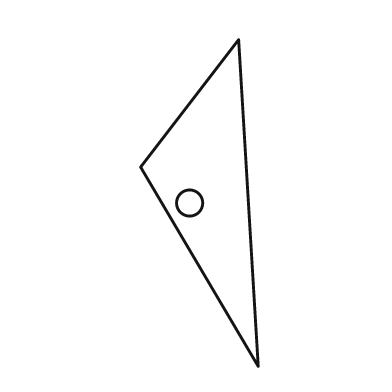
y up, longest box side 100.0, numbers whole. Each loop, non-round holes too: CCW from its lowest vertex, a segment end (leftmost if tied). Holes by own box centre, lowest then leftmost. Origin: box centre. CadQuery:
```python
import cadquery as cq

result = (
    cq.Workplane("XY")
    .moveTo(18.0, -50.0)
    .lineTo(12.0, 50.0)
    .lineTo(-18.0, 11.0)
    .close()
    .moveTo(-3.0, 0.0)
    .circle(4.0)
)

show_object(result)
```